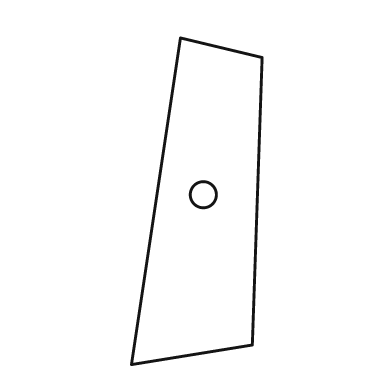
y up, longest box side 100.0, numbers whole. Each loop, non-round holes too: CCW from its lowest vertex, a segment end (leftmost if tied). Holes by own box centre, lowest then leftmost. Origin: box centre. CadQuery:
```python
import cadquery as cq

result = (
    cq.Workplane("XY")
    .moveTo(-20.0, -50.0)
    .lineTo(17.0, -44.0)
    .lineTo(20.0, 44.0)
    .lineTo(-5.0, 50.0)
    .close()
    .moveTo(2.0, 2.0)
    .circle(4.0)
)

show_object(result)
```